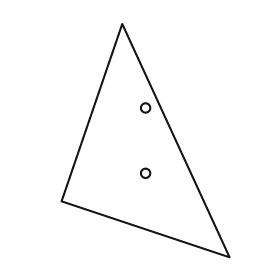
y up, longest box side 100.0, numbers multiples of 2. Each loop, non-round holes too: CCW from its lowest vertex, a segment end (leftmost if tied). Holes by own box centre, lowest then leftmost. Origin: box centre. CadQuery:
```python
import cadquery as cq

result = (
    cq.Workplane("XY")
    .moveTo(36.0, -50.0)
    .lineTo(-10.0, 50.0)
    .lineTo(-36.0, -26.0)
    .close()
    .moveTo(0.0, -14.0)
    .circle(2.0)
    .moveTo(0.0, 14.0)
    .circle(2.0)
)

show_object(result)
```